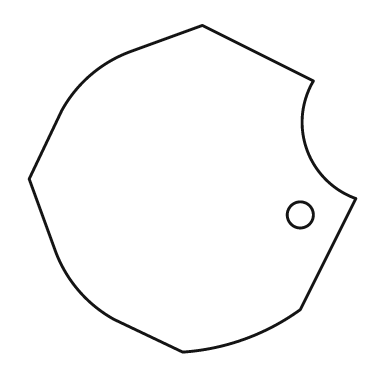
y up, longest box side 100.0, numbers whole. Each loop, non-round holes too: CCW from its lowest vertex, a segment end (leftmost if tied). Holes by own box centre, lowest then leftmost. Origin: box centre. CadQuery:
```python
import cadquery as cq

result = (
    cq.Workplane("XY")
    .moveTo(-3.0, -50.0)
    .threePointArc((16.0, -46.0), (33.0, -37.0))
    .lineTo(50.0, -3.0)
    .threePointArc((35.0, 12.0), (37.0, 33.0))
    .lineTo(3.0, 50.0)
    .lineTo(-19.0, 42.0)
    .threePointArc((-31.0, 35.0), (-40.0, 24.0))
    .lineTo(-50.0, 3.0)
    .lineTo(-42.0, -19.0)
    .threePointArc((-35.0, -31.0), (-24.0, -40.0))
    .close()
    .moveTo(33.0, -8.0)
    .circle(4.0)
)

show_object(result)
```